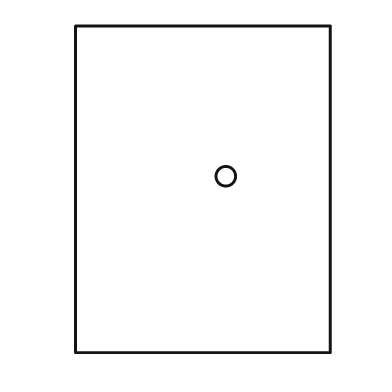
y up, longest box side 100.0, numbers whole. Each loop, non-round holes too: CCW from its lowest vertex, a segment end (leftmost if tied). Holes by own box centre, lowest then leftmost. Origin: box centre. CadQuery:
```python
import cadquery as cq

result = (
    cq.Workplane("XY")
    .moveTo(-39.0, -50.0)
    .lineTo(39.0, -50.0)
    .lineTo(39.0, 50.0)
    .lineTo(-39.0, 50.0)
    .close()
    .moveTo(7.0, 4.0)
    .circle(3.0)
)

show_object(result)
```